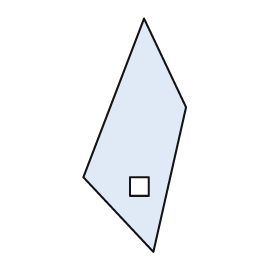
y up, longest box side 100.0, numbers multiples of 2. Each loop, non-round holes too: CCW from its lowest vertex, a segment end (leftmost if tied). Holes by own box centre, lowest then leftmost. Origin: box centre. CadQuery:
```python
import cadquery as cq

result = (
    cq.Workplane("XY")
    .moveTo(8.0, -50.0)
    .lineTo(22.0, 12.0)
    .lineTo(4.0, 50.0)
    .lineTo(-22.0, -18.0)
    .close()
    .moveTo(-2.0, -26.0)
    .lineTo(6.0, -26.0)
    .lineTo(6.0, -18.0)
    .lineTo(-2.0, -18.0)
    .close()
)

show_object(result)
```